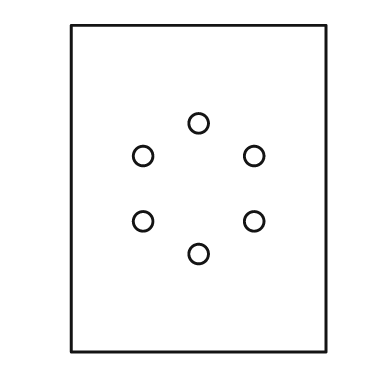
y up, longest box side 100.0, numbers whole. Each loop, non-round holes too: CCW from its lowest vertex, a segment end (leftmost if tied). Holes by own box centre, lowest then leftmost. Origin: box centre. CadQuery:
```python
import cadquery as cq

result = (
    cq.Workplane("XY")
    .moveTo(-39.0, -50.0)
    .lineTo(39.0, -50.0)
    .lineTo(39.0, 50.0)
    .lineTo(-39.0, 50.0)
    .close()
    .moveTo(0.0, -20.0)
    .circle(3.0)
    .moveTo(-17.0, -10.0)
    .circle(3.0)
    .moveTo(17.0, -10.0)
    .circle(3.0)
    .moveTo(-17.0, 10.0)
    .circle(3.0)
    .moveTo(17.0, 10.0)
    .circle(3.0)
    .moveTo(0.0, 20.0)
    .circle(3.0)
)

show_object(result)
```